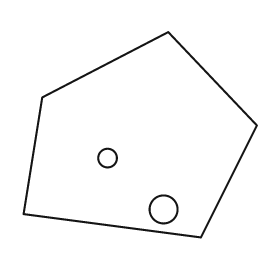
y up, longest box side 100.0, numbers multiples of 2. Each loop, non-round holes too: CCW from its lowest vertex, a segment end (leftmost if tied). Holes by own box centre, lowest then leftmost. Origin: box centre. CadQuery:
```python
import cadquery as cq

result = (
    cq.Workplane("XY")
    .moveTo(26.0, -44.0)
    .lineTo(50.0, 4.0)
    .lineTo(12.0, 44.0)
    .lineTo(-42.0, 16.0)
    .lineTo(-50.0, -34.0)
    .close()
    .moveTo(10.0, -32.0)
    .circle(6.0)
    .moveTo(-14.0, -10.0)
    .circle(4.0)
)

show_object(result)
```